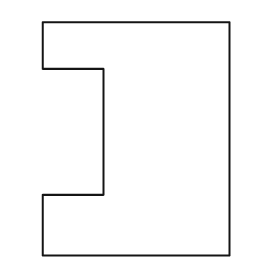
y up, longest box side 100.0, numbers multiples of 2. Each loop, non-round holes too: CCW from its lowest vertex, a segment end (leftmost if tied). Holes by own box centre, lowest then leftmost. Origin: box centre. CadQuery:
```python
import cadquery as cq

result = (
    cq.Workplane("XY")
    .moveTo(-40.0, -50.0)
    .lineTo(40.0, -50.0)
    .lineTo(40.0, 50.0)
    .lineTo(-40.0, 50.0)
    .lineTo(-40.0, 30.0)
    .lineTo(-14.0, 30.0)
    .lineTo(-14.0, -24.0)
    .lineTo(-40.0, -24.0)
    .close()
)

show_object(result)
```